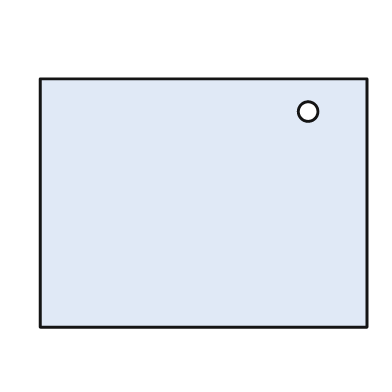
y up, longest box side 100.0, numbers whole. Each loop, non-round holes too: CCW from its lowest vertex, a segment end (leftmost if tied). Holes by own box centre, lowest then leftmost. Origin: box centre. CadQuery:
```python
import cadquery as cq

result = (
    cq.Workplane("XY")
    .moveTo(-50.0, -38.0)
    .lineTo(50.0, -38.0)
    .lineTo(50.0, 38.0)
    .lineTo(-50.0, 38.0)
    .close()
    .moveTo(32.0, 28.0)
    .circle(3.0)
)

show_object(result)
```